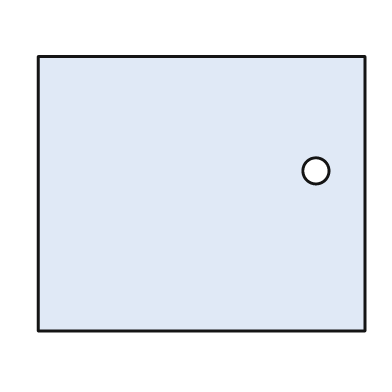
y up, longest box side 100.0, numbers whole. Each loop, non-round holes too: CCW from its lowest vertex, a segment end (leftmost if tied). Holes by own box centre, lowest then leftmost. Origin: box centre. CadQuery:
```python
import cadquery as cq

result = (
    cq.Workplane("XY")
    .moveTo(-50.0, -42.0)
    .lineTo(50.0, -42.0)
    .lineTo(50.0, 42.0)
    .lineTo(-50.0, 42.0)
    .close()
    .moveTo(35.0, 7.0)
    .circle(4.0)
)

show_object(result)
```